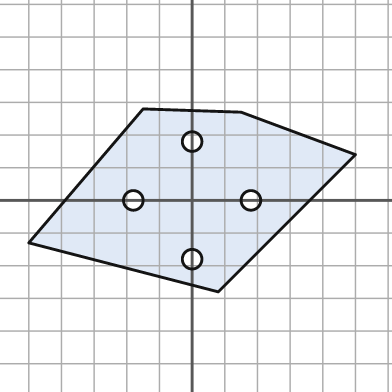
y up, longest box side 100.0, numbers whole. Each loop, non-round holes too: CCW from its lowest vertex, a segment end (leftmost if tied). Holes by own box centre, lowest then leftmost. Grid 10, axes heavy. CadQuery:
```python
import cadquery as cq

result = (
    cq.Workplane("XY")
    .moveTo(8.0, -28.0)
    .lineTo(50.0, 14.0)
    .lineTo(15.0, 27.0)
    .lineTo(-15.0, 28.0)
    .lineTo(-50.0, -13.0)
    .close()
    .moveTo(0.0, -18.0)
    .circle(3.0)
    .moveTo(-18.0, 0.0)
    .circle(3.0)
    .moveTo(18.0, 0.0)
    .circle(3.0)
    .moveTo(0.0, 18.0)
    .circle(3.0)
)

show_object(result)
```